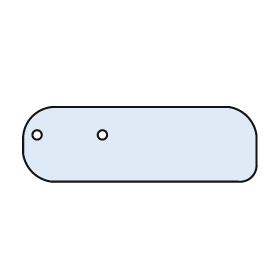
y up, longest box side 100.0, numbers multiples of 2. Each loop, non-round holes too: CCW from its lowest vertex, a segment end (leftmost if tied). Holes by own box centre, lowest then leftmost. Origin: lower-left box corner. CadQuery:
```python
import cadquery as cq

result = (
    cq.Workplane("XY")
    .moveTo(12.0, 0.0)
    .lineTo(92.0, 0.0)
    .threePointArc((98.0, 2.0), (100.0, 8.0))
    .lineTo(100.0, 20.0)
    .threePointArc((96.0, 28.0), (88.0, 32.0))
    .lineTo(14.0, 32.0)
    .threePointArc((4.0, 28.0), (0.0, 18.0))
    .lineTo(0.0, 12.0)
    .threePointArc((4.0, 4.0), (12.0, 0.0))
    .close()
    .moveTo(6.0, 20.0)
    .circle(2.0)
    .moveTo(34.0, 20.0)
    .circle(2.0)
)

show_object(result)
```